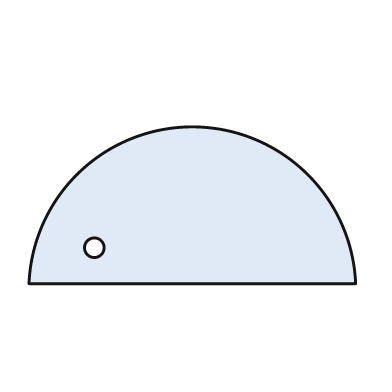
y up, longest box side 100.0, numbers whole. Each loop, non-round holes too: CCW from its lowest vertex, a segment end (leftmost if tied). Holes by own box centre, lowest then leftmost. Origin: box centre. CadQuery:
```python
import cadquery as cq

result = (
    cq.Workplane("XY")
    .moveTo(-50.0, -24.0)
    .lineTo(50.0, -24.0)
    .threePointArc((0.0, 24.0), (-50.0, -24.0))
    .close()
    .moveTo(-30.0, -13.0)
    .circle(3.0)
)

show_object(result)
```